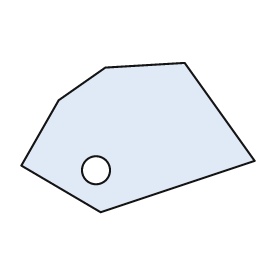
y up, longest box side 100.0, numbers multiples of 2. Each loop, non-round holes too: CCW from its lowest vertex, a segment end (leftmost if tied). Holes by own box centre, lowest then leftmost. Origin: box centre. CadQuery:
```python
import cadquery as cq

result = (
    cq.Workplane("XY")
    .moveTo(-16.0, -32.0)
    .lineTo(50.0, -10.0)
    .lineTo(20.0, 32.0)
    .lineTo(-14.0, 30.0)
    .lineTo(-34.0, 16.0)
    .lineTo(-50.0, -12.0)
    .close()
    .moveTo(-18.0, -14.0)
    .circle(6.0)
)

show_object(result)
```